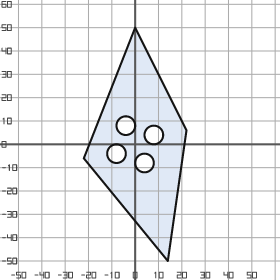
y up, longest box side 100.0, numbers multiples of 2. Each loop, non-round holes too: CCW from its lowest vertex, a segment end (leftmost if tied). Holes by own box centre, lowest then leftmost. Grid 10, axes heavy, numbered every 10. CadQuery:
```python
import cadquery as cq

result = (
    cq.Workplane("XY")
    .moveTo(14.0, -50.0)
    .lineTo(22.0, 6.0)
    .lineTo(0.0, 50.0)
    .lineTo(-22.0, -6.0)
    .close()
    .moveTo(4.0, -8.0)
    .circle(4.0)
    .moveTo(-8.0, -4.0)
    .circle(4.0)
    .moveTo(8.0, 4.0)
    .circle(4.0)
    .moveTo(-4.0, 8.0)
    .circle(4.0)
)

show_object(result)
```